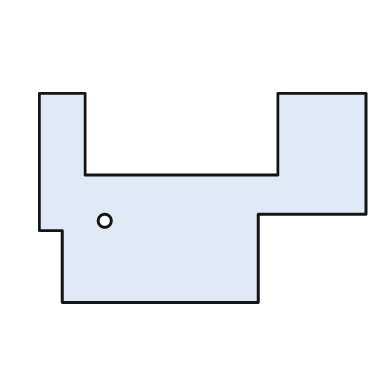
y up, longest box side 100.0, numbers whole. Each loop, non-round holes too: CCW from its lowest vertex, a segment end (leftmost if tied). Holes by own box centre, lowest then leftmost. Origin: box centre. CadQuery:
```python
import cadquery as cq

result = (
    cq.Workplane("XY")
    .moveTo(-43.0, -32.0)
    .lineTo(17.0, -32.0)
    .lineTo(17.0, -5.0)
    .lineTo(50.0, -5.0)
    .lineTo(50.0, 32.0)
    .lineTo(23.0, 32.0)
    .lineTo(23.0, 7.0)
    .lineTo(-36.0, 7.0)
    .lineTo(-36.0, 32.0)
    .lineTo(-50.0, 32.0)
    .lineTo(-50.0, -10.0)
    .lineTo(-43.0, -10.0)
    .close()
    .moveTo(-30.0, -7.0)
    .circle(2.0)
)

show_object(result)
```